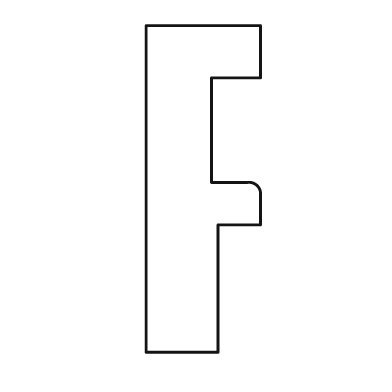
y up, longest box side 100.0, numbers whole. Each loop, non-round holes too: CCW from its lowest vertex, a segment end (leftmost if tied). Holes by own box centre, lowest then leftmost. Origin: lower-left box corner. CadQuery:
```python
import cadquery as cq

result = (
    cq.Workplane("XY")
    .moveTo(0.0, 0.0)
    .lineTo(22.0, 0.0)
    .lineTo(22.0, 39.0)
    .lineTo(35.0, 39.0)
    .lineTo(35.0, 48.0)
    .threePointArc((34.0, 51.0), (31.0, 52.0))
    .lineTo(20.0, 52.0)
    .lineTo(20.0, 84.0)
    .lineTo(35.0, 84.0)
    .lineTo(35.0, 100.0)
    .lineTo(0.0, 100.0)
    .close()
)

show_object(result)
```